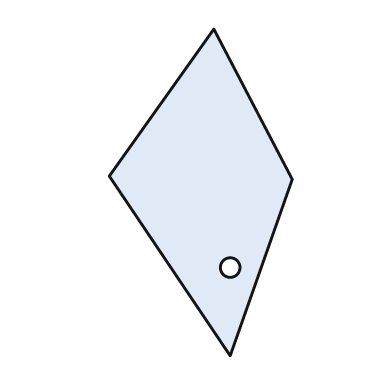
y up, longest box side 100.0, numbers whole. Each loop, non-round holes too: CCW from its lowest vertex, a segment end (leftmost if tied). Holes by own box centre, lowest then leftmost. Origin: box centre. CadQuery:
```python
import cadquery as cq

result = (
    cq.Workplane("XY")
    .moveTo(9.0, -50.0)
    .lineTo(28.0, 4.0)
    .lineTo(4.0, 50.0)
    .lineTo(-28.0, 5.0)
    .close()
    .moveTo(9.0, -23.0)
    .circle(3.0)
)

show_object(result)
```